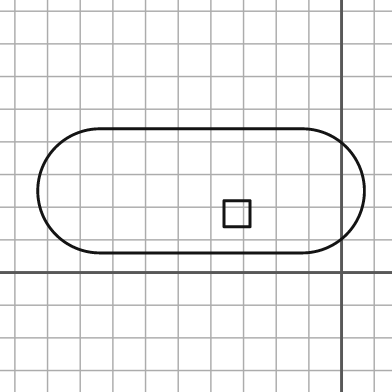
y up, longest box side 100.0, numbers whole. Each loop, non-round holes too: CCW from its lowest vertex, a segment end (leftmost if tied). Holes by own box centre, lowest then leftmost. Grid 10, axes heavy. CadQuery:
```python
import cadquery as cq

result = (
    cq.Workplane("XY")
    .moveTo(-74.0, 6.0)
    .lineTo(-12.0, 6.0)
    .threePointArc((7.0, 25.0), (-12.0, 44.0))
    .lineTo(-74.0, 44.0)
    .threePointArc((-93.0, 25.0), (-74.0, 6.0))
    .close()
    .moveTo(-36.0, 14.0)
    .lineTo(-28.0, 14.0)
    .lineTo(-28.0, 22.0)
    .lineTo(-36.0, 22.0)
    .close()
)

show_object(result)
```